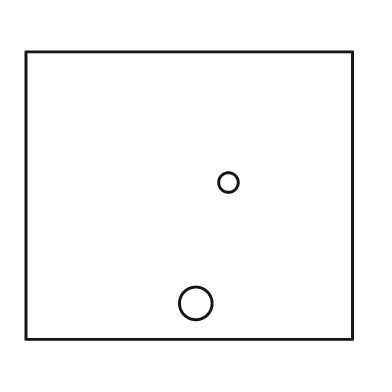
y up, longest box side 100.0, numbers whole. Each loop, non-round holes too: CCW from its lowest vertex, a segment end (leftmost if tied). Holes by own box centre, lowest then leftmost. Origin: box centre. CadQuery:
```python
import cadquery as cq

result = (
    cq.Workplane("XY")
    .moveTo(-50.0, -44.0)
    .lineTo(50.0, -44.0)
    .lineTo(50.0, 44.0)
    .lineTo(-50.0, 44.0)
    .close()
    .moveTo(2.0, -33.0)
    .circle(5.0)
    .moveTo(12.0, 4.0)
    .circle(3.0)
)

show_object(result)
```